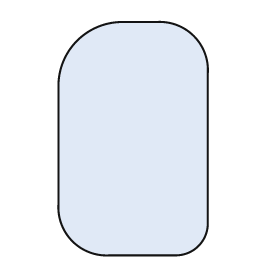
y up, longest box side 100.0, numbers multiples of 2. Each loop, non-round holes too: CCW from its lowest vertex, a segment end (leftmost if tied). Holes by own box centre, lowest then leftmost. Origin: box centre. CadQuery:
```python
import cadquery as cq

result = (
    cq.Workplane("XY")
    .moveTo(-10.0, -50.0)
    .lineTo(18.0, -50.0)
    .threePointArc((28.0, -46.0), (32.0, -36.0))
    .lineTo(32.0, 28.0)
    .threePointArc((26.0, 44.0), (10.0, 50.0))
    .lineTo(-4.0, 50.0)
    .threePointArc((-24.0, 42.0), (-32.0, 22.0))
    .lineTo(-32.0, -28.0)
    .threePointArc((-26.0, -44.0), (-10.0, -50.0))
    .close()
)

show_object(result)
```